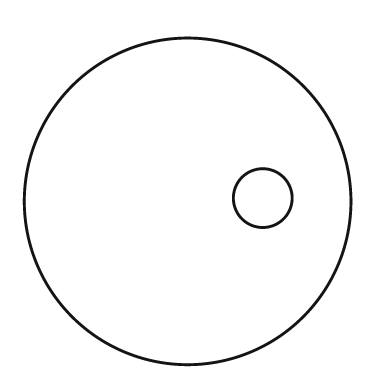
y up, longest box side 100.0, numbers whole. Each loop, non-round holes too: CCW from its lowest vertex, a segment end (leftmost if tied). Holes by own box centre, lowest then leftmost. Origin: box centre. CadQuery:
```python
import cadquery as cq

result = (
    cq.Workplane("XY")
    .moveTo(0.0, 0.0)
    .circle(50.0)
    .moveTo(23.0, 1.0)
    .circle(9.0)
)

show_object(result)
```